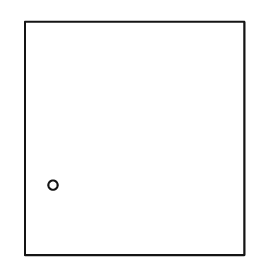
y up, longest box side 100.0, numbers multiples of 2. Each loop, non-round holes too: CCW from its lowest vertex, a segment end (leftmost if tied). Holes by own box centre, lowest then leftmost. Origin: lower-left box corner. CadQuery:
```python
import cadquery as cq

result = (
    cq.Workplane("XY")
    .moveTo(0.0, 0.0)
    .lineTo(94.0, 0.0)
    .lineTo(94.0, 100.0)
    .lineTo(0.0, 100.0)
    .close()
    .moveTo(12.0, 30.0)
    .circle(2.0)
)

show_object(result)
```